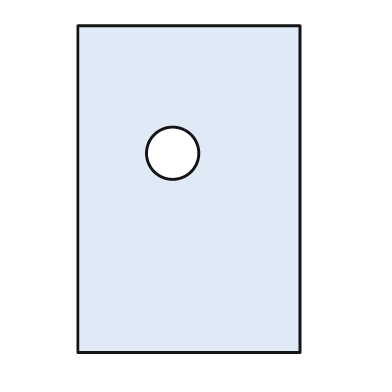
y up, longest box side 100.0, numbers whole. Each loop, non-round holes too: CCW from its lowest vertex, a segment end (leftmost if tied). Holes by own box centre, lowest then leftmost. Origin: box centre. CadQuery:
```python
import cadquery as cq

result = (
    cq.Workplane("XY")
    .moveTo(-34.0, -50.0)
    .lineTo(34.0, -50.0)
    .lineTo(34.0, 50.0)
    .lineTo(-34.0, 50.0)
    .close()
    .moveTo(-5.0, 11.0)
    .circle(8.0)
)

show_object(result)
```